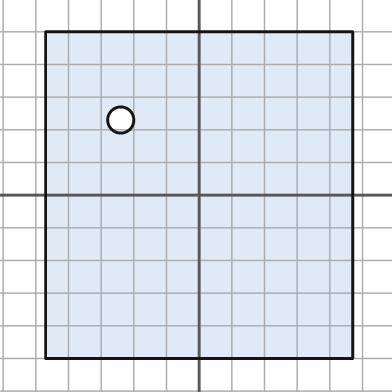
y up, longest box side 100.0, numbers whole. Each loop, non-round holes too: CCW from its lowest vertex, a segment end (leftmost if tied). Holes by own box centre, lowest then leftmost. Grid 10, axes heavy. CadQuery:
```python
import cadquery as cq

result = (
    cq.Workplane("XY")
    .moveTo(-47.0, -50.0)
    .lineTo(47.0, -50.0)
    .lineTo(47.0, 50.0)
    .lineTo(-47.0, 50.0)
    .close()
    .moveTo(-24.0, 23.0)
    .circle(4.0)
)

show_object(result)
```